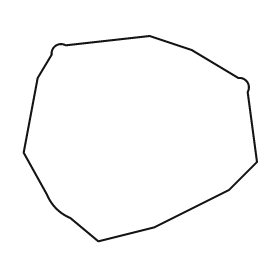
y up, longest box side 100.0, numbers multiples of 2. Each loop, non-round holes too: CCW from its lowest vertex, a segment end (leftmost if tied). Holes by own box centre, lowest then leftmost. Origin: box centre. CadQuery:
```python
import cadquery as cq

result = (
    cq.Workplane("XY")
    .moveTo(-18.0, -44.0)
    .lineTo(6.0, -38.0)
    .lineTo(38.0, -22.0)
    .lineTo(50.0, -10.0)
    .lineTo(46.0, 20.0)
    .threePointArc((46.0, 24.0), (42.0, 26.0))
    .lineTo(22.0, 38.0)
    .lineTo(4.0, 44.0)
    .lineTo(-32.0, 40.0)
    .threePointArc((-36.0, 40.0), (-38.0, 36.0))
    .lineTo(-44.0, 26.0)
    .lineTo(-50.0, -6.0)
    .lineTo(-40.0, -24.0)
    .threePointArc((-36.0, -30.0), (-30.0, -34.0))
    .close()
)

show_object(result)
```